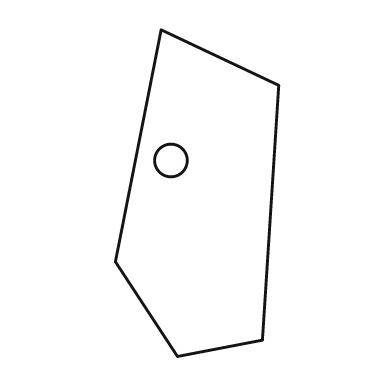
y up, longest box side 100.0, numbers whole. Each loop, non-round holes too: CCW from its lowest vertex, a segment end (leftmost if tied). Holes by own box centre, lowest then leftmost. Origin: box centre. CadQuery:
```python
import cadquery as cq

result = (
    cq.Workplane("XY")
    .moveTo(-6.0, -50.0)
    .lineTo(20.0, -45.0)
    .lineTo(25.0, 33.0)
    .lineTo(-11.0, 50.0)
    .lineTo(-25.0, -21.0)
    .close()
    .moveTo(-8.0, 10.0)
    .circle(5.0)
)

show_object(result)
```